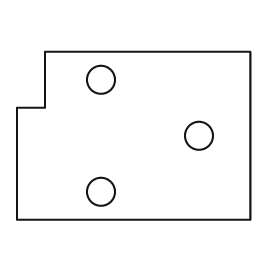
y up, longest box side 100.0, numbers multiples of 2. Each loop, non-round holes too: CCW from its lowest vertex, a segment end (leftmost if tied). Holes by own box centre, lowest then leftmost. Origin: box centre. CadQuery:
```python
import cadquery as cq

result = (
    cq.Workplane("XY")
    .moveTo(-50.0, -36.0)
    .lineTo(50.0, -36.0)
    .lineTo(50.0, 36.0)
    .lineTo(-38.0, 36.0)
    .lineTo(-38.0, 12.0)
    .lineTo(-50.0, 12.0)
    .close()
    .moveTo(-14.0, -24.0)
    .circle(6.0)
    .moveTo(28.0, 0.0)
    .circle(6.0)
    .moveTo(-14.0, 24.0)
    .circle(6.0)
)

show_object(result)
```